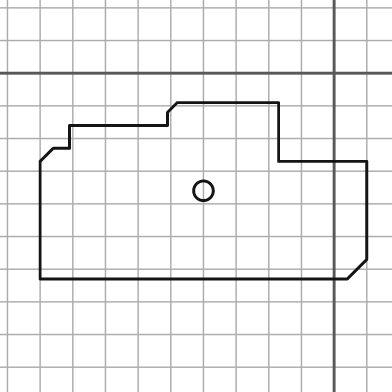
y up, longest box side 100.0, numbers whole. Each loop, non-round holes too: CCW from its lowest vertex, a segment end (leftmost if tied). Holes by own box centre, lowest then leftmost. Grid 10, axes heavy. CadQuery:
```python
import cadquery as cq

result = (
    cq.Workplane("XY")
    .moveTo(-90.0, -63.0)
    .lineTo(4.0, -63.0)
    .lineTo(10.0, -57.0)
    .lineTo(10.0, -27.0)
    .lineTo(-17.0, -27.0)
    .lineTo(-17.0, -9.0)
    .lineTo(-48.0, -9.0)
    .lineTo(-51.0, -12.0)
    .lineTo(-51.0, -16.0)
    .lineTo(-81.0, -16.0)
    .lineTo(-81.0, -23.0)
    .lineTo(-86.0, -23.0)
    .lineTo(-90.0, -27.0)
    .close()
    .moveTo(-40.0, -36.0)
    .circle(3.0)
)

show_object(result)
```